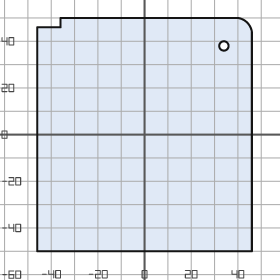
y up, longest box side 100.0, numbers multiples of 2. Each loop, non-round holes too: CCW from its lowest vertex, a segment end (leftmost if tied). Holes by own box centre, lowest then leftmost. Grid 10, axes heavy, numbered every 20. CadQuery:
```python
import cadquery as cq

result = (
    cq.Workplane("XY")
    .moveTo(-46.0, -50.0)
    .lineTo(46.0, -50.0)
    .lineTo(46.0, 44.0)
    .threePointArc((44.0, 48.0), (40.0, 50.0))
    .lineTo(-36.0, 50.0)
    .lineTo(-36.0, 46.0)
    .lineTo(-46.0, 46.0)
    .close()
    .moveTo(34.0, 38.0)
    .circle(2.0)
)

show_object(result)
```